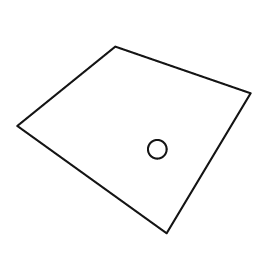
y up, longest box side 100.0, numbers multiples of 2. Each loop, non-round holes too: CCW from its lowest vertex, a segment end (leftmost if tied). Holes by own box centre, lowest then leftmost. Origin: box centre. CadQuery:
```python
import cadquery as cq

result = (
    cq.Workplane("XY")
    .moveTo(14.0, -40.0)
    .lineTo(50.0, 20.0)
    .lineTo(-8.0, 40.0)
    .lineTo(-50.0, 6.0)
    .close()
    .moveTo(10.0, -4.0)
    .circle(4.0)
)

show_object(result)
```